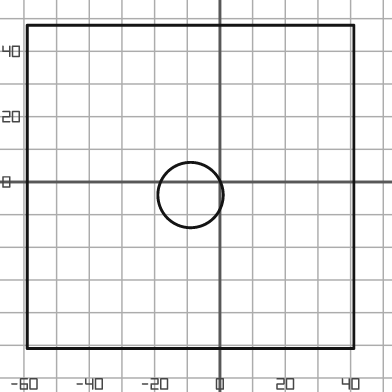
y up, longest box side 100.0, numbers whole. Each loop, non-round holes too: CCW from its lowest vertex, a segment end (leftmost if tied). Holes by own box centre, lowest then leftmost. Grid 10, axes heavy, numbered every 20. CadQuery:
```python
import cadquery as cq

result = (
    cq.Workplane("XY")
    .moveTo(-59.0, -51.0)
    .lineTo(41.0, -51.0)
    .lineTo(41.0, 48.0)
    .lineTo(-59.0, 48.0)
    .close()
    .moveTo(-9.0, -4.0)
    .circle(10.0)
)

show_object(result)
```